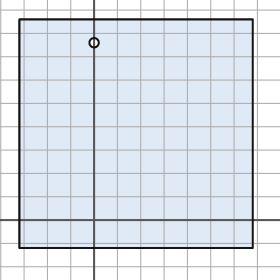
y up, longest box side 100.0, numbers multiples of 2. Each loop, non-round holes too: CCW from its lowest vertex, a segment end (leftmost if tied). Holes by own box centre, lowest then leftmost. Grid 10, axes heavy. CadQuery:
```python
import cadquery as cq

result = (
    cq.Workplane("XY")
    .moveTo(-32.0, -12.0)
    .lineTo(68.0, -12.0)
    .lineTo(68.0, 86.0)
    .lineTo(-32.0, 86.0)
    .close()
    .moveTo(0.0, 76.0)
    .circle(2.0)
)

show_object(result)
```